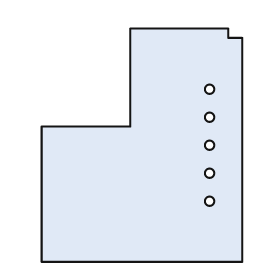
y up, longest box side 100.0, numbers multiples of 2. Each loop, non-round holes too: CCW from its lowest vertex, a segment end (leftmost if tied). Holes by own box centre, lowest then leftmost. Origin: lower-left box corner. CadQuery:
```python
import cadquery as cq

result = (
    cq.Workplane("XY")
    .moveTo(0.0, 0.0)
    .lineTo(86.0, 0.0)
    .lineTo(86.0, 96.0)
    .lineTo(80.0, 96.0)
    .lineTo(80.0, 100.0)
    .lineTo(38.0, 100.0)
    .lineTo(38.0, 58.0)
    .lineTo(0.0, 58.0)
    .close()
    .moveTo(72.0, 26.0)
    .circle(2.0)
    .moveTo(72.0, 38.0)
    .circle(2.0)
    .moveTo(72.0, 50.0)
    .circle(2.0)
    .moveTo(72.0, 62.0)
    .circle(2.0)
    .moveTo(72.0, 74.0)
    .circle(2.0)
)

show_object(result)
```